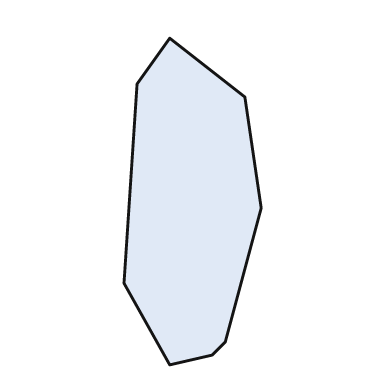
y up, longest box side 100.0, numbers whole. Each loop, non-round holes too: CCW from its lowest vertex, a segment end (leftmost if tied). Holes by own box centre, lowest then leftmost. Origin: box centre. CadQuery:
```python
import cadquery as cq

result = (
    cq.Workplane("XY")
    .moveTo(-7.0, -50.0)
    .lineTo(6.0, -47.0)
    .lineTo(10.0, -43.0)
    .lineTo(21.0, -2.0)
    .lineTo(16.0, 32.0)
    .lineTo(-7.0, 50.0)
    .lineTo(-17.0, 36.0)
    .lineTo(-21.0, -25.0)
    .close()
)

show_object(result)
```